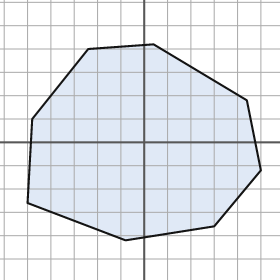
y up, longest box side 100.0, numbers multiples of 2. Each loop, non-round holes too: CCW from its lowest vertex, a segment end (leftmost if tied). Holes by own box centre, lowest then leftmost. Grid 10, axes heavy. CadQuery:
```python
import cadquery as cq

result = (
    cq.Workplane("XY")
    .moveTo(-8.0, -42.0)
    .lineTo(30.0, -36.0)
    .lineTo(50.0, -12.0)
    .lineTo(44.0, 18.0)
    .lineTo(4.0, 42.0)
    .lineTo(-24.0, 40.0)
    .lineTo(-48.0, 10.0)
    .lineTo(-50.0, -26.0)
    .close()
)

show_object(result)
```